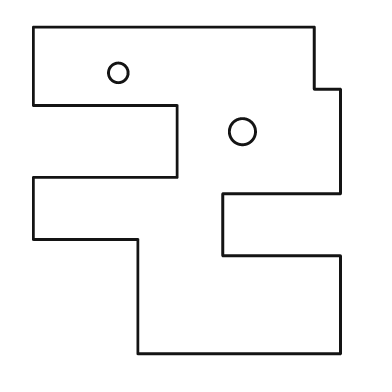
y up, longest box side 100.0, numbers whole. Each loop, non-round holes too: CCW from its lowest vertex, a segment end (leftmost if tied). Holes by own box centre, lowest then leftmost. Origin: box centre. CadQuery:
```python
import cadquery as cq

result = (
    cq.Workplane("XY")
    .moveTo(-15.0, -50.0)
    .lineTo(47.0, -50.0)
    .lineTo(47.0, -20.0)
    .lineTo(11.0, -20.0)
    .lineTo(11.0, -1.0)
    .lineTo(47.0, -1.0)
    .lineTo(47.0, 31.0)
    .lineTo(39.0, 31.0)
    .lineTo(39.0, 50.0)
    .lineTo(-47.0, 50.0)
    .lineTo(-47.0, 26.0)
    .lineTo(-3.0, 26.0)
    .lineTo(-3.0, 4.0)
    .lineTo(-47.0, 4.0)
    .lineTo(-47.0, -15.0)
    .lineTo(-15.0, -15.0)
    .close()
    .moveTo(17.0, 18.0)
    .circle(4.0)
    .moveTo(-21.0, 36.0)
    .circle(3.0)
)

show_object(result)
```